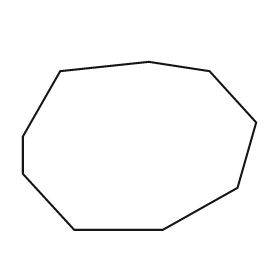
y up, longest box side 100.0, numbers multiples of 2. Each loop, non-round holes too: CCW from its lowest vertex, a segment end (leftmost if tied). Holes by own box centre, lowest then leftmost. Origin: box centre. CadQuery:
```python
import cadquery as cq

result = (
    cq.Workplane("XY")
    .moveTo(-28.0, -36.0)
    .lineTo(10.0, -36.0)
    .lineTo(42.0, -18.0)
    .lineTo(50.0, 10.0)
    .lineTo(30.0, 32.0)
    .lineTo(4.0, 36.0)
    .lineTo(-34.0, 32.0)
    .lineTo(-50.0, 4.0)
    .lineTo(-50.0, -12.0)
    .close()
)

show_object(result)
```